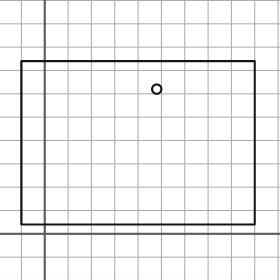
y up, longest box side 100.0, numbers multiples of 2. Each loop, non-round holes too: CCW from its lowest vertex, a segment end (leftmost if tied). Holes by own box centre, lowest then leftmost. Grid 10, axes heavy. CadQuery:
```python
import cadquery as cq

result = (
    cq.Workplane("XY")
    .moveTo(-10.0, 4.0)
    .lineTo(90.0, 4.0)
    .lineTo(90.0, 74.0)
    .lineTo(-10.0, 74.0)
    .close()
    .moveTo(48.0, 62.0)
    .circle(2.0)
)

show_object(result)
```